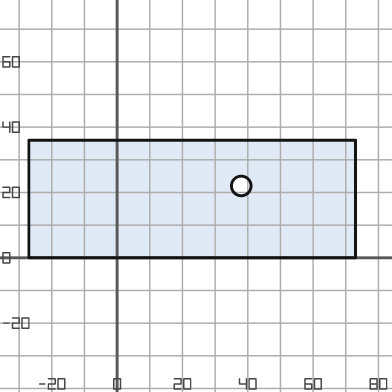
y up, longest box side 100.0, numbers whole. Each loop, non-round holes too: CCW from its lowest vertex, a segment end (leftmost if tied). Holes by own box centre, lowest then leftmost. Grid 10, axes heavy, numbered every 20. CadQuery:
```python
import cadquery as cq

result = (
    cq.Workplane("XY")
    .moveTo(-27.0, 0.0)
    .lineTo(73.0, 0.0)
    .lineTo(73.0, 36.0)
    .lineTo(-27.0, 36.0)
    .close()
    .moveTo(38.0, 22.0)
    .circle(3.0)
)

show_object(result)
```